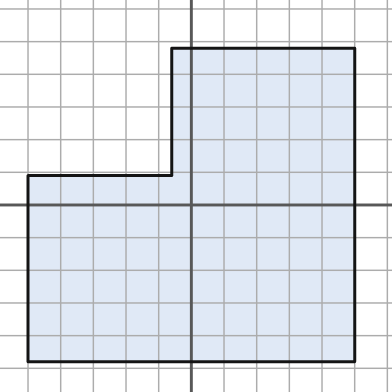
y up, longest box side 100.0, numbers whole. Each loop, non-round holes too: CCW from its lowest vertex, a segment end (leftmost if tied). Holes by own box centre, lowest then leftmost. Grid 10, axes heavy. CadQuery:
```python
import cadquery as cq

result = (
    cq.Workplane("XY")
    .moveTo(-50.0, -48.0)
    .lineTo(50.0, -48.0)
    .lineTo(50.0, 48.0)
    .lineTo(-6.0, 48.0)
    .lineTo(-6.0, 9.0)
    .lineTo(-50.0, 9.0)
    .close()
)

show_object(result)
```